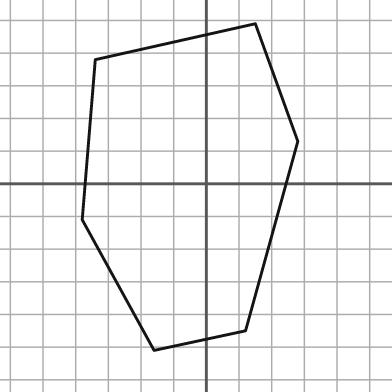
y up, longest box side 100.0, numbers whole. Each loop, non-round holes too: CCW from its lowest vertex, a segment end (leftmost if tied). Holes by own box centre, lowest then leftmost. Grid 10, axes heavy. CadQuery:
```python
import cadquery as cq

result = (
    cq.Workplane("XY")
    .moveTo(-16.0, -51.0)
    .lineTo(12.0, -45.0)
    .lineTo(28.0, 13.0)
    .lineTo(15.0, 49.0)
    .lineTo(-34.0, 38.0)
    .lineTo(-38.0, -11.0)
    .close()
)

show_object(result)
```